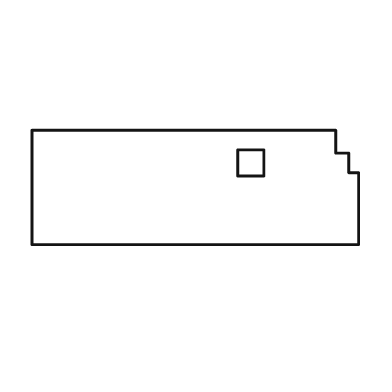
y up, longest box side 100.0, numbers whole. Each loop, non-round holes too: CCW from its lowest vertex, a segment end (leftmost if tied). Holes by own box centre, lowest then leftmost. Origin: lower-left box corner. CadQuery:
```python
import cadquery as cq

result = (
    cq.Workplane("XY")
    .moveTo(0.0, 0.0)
    .lineTo(100.0, 0.0)
    .lineTo(100.0, 22.0)
    .lineTo(97.0, 22.0)
    .lineTo(97.0, 28.0)
    .lineTo(93.0, 28.0)
    .lineTo(93.0, 35.0)
    .lineTo(0.0, 35.0)
    .close()
    .moveTo(63.0, 21.0)
    .lineTo(71.0, 21.0)
    .lineTo(71.0, 29.0)
    .lineTo(63.0, 29.0)
    .close()
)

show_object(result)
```